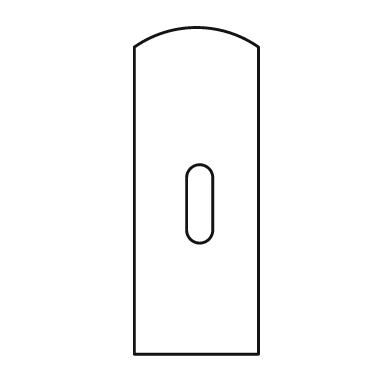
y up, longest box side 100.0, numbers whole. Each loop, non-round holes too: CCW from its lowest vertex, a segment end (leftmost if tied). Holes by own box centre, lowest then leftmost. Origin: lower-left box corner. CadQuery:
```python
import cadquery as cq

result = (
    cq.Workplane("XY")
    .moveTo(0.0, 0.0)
    .lineTo(38.0, 0.0)
    .lineTo(38.0, 94.0)
    .threePointArc((19.0, 100.0), (0.0, 94.0))
    .close()
    .moveTo(16.0, 38.0)
    .threePointArc((20.0, 34.0), (24.0, 38.0))
    .lineTo(24.0, 54.0)
    .threePointArc((20.0, 58.0), (16.0, 54.0))
    .close()
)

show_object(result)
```